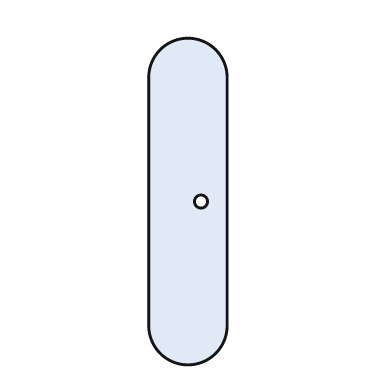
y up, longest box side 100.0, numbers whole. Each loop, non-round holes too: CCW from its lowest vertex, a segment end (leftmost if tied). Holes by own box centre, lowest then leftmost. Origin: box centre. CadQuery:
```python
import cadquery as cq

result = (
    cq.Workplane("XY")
    .moveTo(-12.0, -38.0)
    .threePointArc((0.0, -50.0), (12.0, -38.0))
    .lineTo(12.0, 38.0)
    .threePointArc((0.0, 50.0), (-12.0, 38.0))
    .close()
    .moveTo(4.0, 0.0)
    .circle(2.0)
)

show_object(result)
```